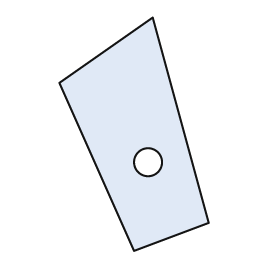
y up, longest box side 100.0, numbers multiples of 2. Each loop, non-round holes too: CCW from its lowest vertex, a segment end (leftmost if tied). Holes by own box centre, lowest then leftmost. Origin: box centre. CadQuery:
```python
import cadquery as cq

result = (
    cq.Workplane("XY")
    .moveTo(0.0, -50.0)
    .lineTo(32.0, -38.0)
    .lineTo(8.0, 50.0)
    .lineTo(-32.0, 22.0)
    .close()
    .moveTo(6.0, -12.0)
    .circle(6.0)
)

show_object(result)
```